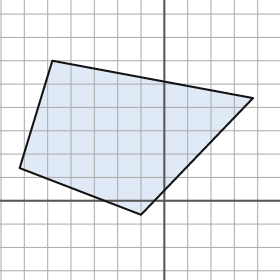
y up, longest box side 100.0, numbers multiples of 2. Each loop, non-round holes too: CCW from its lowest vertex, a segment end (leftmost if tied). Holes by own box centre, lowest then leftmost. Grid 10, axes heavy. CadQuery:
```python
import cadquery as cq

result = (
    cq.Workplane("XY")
    .moveTo(-10.0, -6.0)
    .lineTo(38.0, 44.0)
    .lineTo(-48.0, 60.0)
    .lineTo(-62.0, 14.0)
    .close()
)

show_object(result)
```